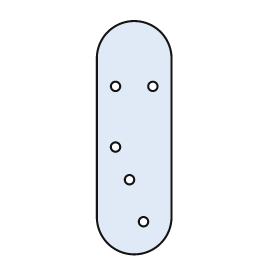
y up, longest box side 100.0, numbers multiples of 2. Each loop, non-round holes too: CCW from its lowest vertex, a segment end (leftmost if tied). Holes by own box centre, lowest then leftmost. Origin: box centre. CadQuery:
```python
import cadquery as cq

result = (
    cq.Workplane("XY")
    .moveTo(-16.0, -34.0)
    .threePointArc((0.0, -50.0), (16.0, -34.0))
    .lineTo(16.0, 34.0)
    .threePointArc((0.0, 50.0), (-16.0, 34.0))
    .close()
    .moveTo(4.0, -36.0)
    .circle(2.0)
    .moveTo(-2.0, -18.0)
    .circle(2.0)
    .moveTo(-8.0, -4.0)
    .circle(2.0)
    .moveTo(-8.0, 22.0)
    .circle(2.0)
    .moveTo(8.0, 22.0)
    .circle(2.0)
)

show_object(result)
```